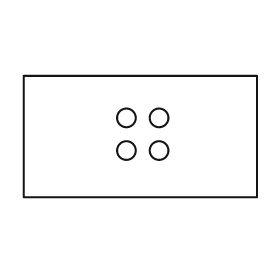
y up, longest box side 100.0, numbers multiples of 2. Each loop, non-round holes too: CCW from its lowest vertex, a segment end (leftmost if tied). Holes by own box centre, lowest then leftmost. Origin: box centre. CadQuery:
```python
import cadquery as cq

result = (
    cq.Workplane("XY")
    .moveTo(-50.0, -26.0)
    .lineTo(50.0, -26.0)
    .lineTo(50.0, 26.0)
    .lineTo(-50.0, 26.0)
    .close()
    .moveTo(-6.0, -6.0)
    .circle(4.0)
    .moveTo(8.0, -6.0)
    .circle(4.0)
    .moveTo(-6.0, 8.0)
    .circle(4.0)
    .moveTo(8.0, 8.0)
    .circle(4.0)
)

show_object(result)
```